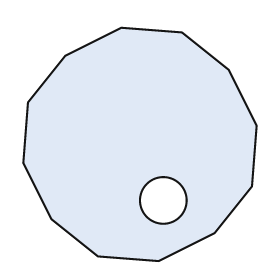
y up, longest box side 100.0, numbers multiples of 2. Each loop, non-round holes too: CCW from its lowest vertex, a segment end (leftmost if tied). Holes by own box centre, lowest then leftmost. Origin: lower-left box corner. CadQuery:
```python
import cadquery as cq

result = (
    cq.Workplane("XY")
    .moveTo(58.0, 0.0)
    .lineTo(82.0, 12.0)
    .lineTo(98.0, 32.0)
    .lineTo(100.0, 58.0)
    .lineTo(88.0, 82.0)
    .lineTo(68.0, 98.0)
    .lineTo(42.0, 100.0)
    .lineTo(18.0, 88.0)
    .lineTo(2.0, 68.0)
    .lineTo(0.0, 42.0)
    .lineTo(12.0, 18.0)
    .lineTo(32.0, 2.0)
    .close()
    .moveTo(60.0, 26.0)
    .circle(10.0)
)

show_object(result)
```